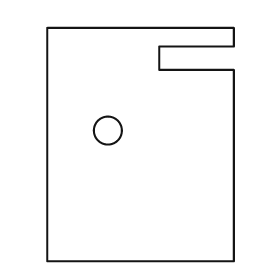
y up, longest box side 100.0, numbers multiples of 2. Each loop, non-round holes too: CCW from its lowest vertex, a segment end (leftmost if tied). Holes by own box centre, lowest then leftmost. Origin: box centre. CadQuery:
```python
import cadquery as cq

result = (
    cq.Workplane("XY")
    .moveTo(-40.0, -50.0)
    .lineTo(40.0, -50.0)
    .lineTo(40.0, 32.0)
    .lineTo(8.0, 32.0)
    .lineTo(8.0, 42.0)
    .lineTo(40.0, 42.0)
    .lineTo(40.0, 50.0)
    .lineTo(-40.0, 50.0)
    .close()
    .moveTo(-14.0, 6.0)
    .circle(6.0)
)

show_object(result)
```